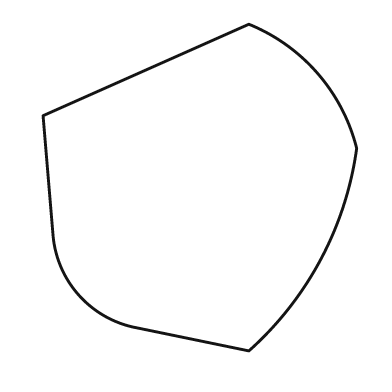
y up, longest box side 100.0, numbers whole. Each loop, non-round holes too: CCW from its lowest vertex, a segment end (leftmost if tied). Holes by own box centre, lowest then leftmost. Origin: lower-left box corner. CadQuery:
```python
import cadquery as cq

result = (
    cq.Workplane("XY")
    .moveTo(63.0, 0.0)
    .threePointArc((85.0, 28.0), (96.0, 62.0))
    .threePointArc((84.0, 85.0), (63.0, 100.0))
    .lineTo(0.0, 72.0)
    .lineTo(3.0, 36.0)
    .threePointArc((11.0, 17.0), (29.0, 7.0))
    .close()
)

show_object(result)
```